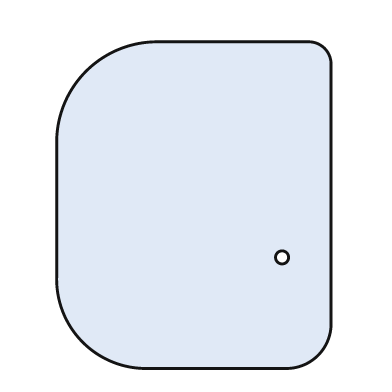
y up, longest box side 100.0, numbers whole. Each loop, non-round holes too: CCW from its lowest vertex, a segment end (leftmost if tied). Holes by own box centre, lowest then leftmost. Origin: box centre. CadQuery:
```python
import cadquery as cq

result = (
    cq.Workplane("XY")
    .moveTo(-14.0, -50.0)
    .lineTo(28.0, -50.0)
    .threePointArc((38.0, -46.0), (42.0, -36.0))
    .lineTo(42.0, 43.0)
    .threePointArc((40.0, 48.0), (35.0, 50.0))
    .lineTo(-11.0, 50.0)
    .threePointArc((-33.0, 41.0), (-42.0, 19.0))
    .lineTo(-42.0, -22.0)
    .threePointArc((-34.0, -42.0), (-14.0, -50.0))
    .close()
    .moveTo(27.0, -16.0)
    .circle(2.0)
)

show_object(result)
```